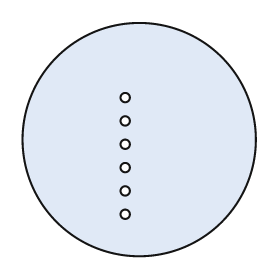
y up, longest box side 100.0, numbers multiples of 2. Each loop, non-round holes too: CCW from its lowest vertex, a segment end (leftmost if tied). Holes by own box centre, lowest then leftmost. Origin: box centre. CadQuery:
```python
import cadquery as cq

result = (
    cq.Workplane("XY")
    .moveTo(0.0, 0.0)
    .circle(50.0)
    .moveTo(-6.0, -32.0)
    .circle(2.0)
    .moveTo(-6.0, -22.0)
    .circle(2.0)
    .moveTo(-6.0, -12.0)
    .circle(2.0)
    .moveTo(-6.0, -2.0)
    .circle(2.0)
    .moveTo(-6.0, 8.0)
    .circle(2.0)
    .moveTo(-6.0, 18.0)
    .circle(2.0)
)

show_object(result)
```